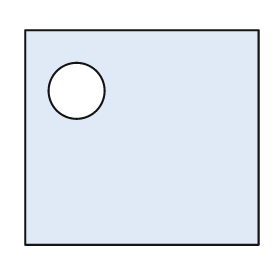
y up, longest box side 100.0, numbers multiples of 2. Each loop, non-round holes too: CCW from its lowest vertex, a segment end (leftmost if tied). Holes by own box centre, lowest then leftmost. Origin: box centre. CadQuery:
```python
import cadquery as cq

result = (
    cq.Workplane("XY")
    .moveTo(-50.0, -46.0)
    .lineTo(50.0, -46.0)
    .lineTo(50.0, 46.0)
    .lineTo(-50.0, 46.0)
    .close()
    .moveTo(-28.0, 20.0)
    .circle(12.0)
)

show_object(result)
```